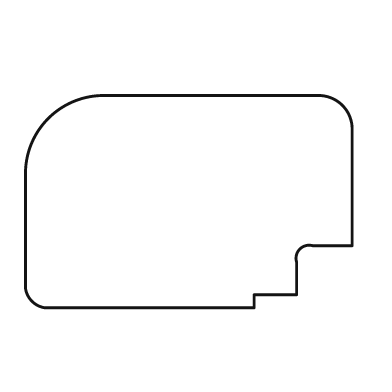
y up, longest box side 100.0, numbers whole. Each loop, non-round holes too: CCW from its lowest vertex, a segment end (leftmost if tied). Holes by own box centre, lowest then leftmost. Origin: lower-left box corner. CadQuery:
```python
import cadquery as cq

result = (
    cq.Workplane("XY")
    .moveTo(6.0, 0.0)
    .lineTo(70.0, 0.0)
    .lineTo(70.0, 4.0)
    .lineTo(83.0, 4.0)
    .lineTo(83.0, 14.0)
    .threePointArc((84.0, 18.0), (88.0, 19.0))
    .lineTo(100.0, 19.0)
    .lineTo(100.0, 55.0)
    .threePointArc((97.0, 62.0), (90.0, 65.0))
    .lineTo(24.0, 65.0)
    .threePointArc((7.0, 58.0), (0.0, 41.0))
    .lineTo(0.0, 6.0)
    .threePointArc((2.0, 2.0), (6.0, 0.0))
    .close()
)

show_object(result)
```